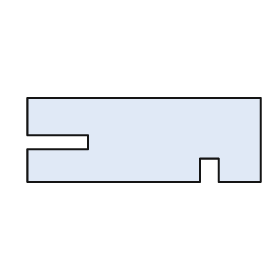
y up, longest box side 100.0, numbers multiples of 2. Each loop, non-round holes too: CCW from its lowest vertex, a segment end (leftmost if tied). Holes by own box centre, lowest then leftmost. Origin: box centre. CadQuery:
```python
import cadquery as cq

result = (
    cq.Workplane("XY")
    .moveTo(-50.0, -18.0)
    .lineTo(24.0, -18.0)
    .lineTo(24.0, -8.0)
    .lineTo(32.0, -8.0)
    .lineTo(32.0, -18.0)
    .lineTo(50.0, -18.0)
    .lineTo(50.0, 18.0)
    .lineTo(-50.0, 18.0)
    .lineTo(-50.0, 2.0)
    .lineTo(-24.0, 2.0)
    .lineTo(-24.0, -4.0)
    .lineTo(-50.0, -4.0)
    .close()
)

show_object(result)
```